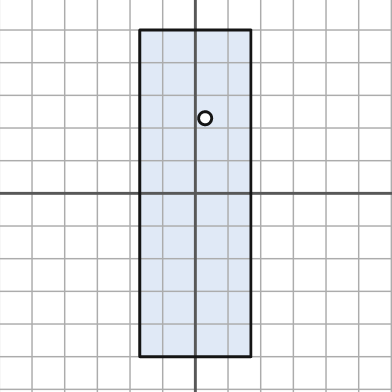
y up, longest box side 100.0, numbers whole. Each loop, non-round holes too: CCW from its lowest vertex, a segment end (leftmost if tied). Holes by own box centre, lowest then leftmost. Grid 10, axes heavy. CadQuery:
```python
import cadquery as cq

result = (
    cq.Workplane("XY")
    .moveTo(-17.0, -50.0)
    .lineTo(17.0, -50.0)
    .lineTo(17.0, 50.0)
    .lineTo(-17.0, 50.0)
    .close()
    .moveTo(3.0, 23.0)
    .circle(2.0)
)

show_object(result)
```